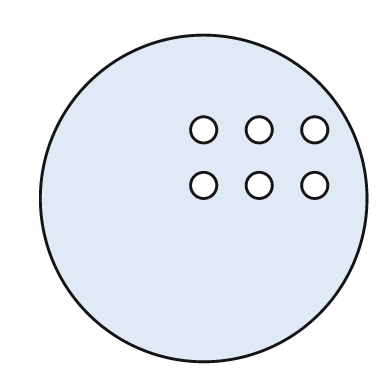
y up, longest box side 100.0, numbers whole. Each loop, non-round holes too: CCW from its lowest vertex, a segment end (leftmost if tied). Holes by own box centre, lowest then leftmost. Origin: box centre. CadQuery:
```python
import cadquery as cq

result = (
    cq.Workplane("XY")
    .moveTo(0.0, 0.0)
    .circle(50.0)
    .moveTo(0.0, 4.0)
    .circle(4.0)
    .moveTo(17.0, 4.0)
    .circle(4.0)
    .moveTo(34.0, 4.0)
    .circle(4.0)
    .moveTo(0.0, 21.0)
    .circle(4.0)
    .moveTo(17.0, 21.0)
    .circle(4.0)
    .moveTo(34.0, 21.0)
    .circle(4.0)
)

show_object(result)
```